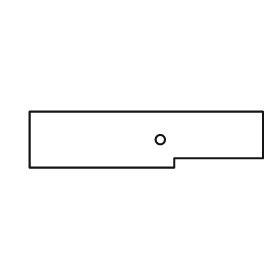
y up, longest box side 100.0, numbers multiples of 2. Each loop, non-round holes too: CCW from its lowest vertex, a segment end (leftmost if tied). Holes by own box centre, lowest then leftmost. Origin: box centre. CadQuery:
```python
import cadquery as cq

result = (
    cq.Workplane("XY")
    .moveTo(-50.0, -12.0)
    .lineTo(12.0, -12.0)
    .lineTo(12.0, -8.0)
    .lineTo(50.0, -8.0)
    .lineTo(50.0, 12.0)
    .lineTo(-50.0, 12.0)
    .close()
    .moveTo(6.0, 0.0)
    .circle(2.0)
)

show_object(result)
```